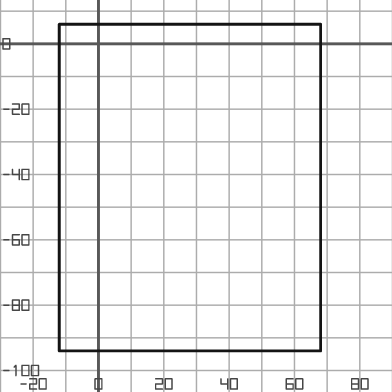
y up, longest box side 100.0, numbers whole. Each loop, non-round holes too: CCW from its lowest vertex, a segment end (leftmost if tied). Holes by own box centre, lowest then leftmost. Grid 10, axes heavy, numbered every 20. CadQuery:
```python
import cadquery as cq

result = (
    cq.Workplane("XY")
    .moveTo(-12.0, -94.0)
    .lineTo(68.0, -94.0)
    .lineTo(68.0, 6.0)
    .lineTo(-12.0, 6.0)
    .close()
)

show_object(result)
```